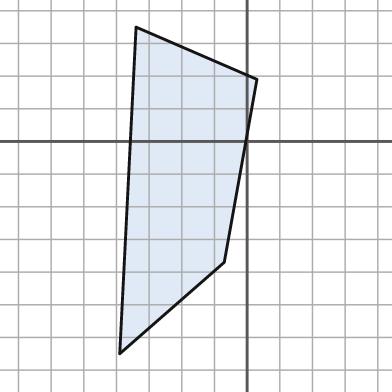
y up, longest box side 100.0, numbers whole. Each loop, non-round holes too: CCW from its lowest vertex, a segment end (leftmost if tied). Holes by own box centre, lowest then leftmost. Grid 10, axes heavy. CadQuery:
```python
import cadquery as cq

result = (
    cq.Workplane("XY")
    .moveTo(-39.0, -65.0)
    .lineTo(-7.0, -37.0)
    .lineTo(3.0, 19.0)
    .lineTo(-34.0, 35.0)
    .close()
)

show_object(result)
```